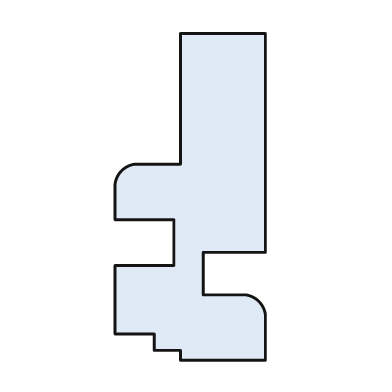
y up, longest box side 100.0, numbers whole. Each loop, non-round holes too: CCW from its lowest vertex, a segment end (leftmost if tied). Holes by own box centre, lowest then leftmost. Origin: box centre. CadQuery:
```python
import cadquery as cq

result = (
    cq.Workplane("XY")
    .moveTo(-3.0, -50.0)
    .lineTo(23.0, -50.0)
    .lineTo(23.0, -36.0)
    .threePointArc((21.0, -32.0), (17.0, -30.0))
    .lineTo(4.0, -30.0)
    .lineTo(4.0, -17.0)
    .lineTo(23.0, -17.0)
    .lineTo(23.0, 50.0)
    .lineTo(-3.0, 50.0)
    .lineTo(-3.0, 10.0)
    .lineTo(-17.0, 10.0)
    .threePointArc((-21.0, 8.0), (-23.0, 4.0))
    .lineTo(-23.0, -7.0)
    .lineTo(-5.0, -7.0)
    .lineTo(-5.0, -21.0)
    .lineTo(-23.0, -21.0)
    .lineTo(-23.0, -42.0)
    .lineTo(-11.0, -42.0)
    .lineTo(-11.0, -47.0)
    .lineTo(-3.0, -47.0)
    .close()
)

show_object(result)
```